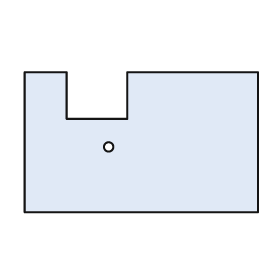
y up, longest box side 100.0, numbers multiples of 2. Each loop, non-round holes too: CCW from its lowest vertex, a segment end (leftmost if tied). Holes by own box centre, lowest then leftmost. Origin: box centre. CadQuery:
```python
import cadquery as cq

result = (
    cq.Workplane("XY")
    .moveTo(-50.0, -30.0)
    .lineTo(50.0, -30.0)
    .lineTo(50.0, 30.0)
    .lineTo(-6.0, 30.0)
    .lineTo(-6.0, 10.0)
    .lineTo(-32.0, 10.0)
    .lineTo(-32.0, 30.0)
    .lineTo(-50.0, 30.0)
    .close()
    .moveTo(-14.0, -2.0)
    .circle(2.0)
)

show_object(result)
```